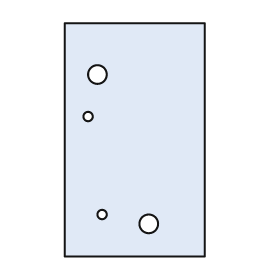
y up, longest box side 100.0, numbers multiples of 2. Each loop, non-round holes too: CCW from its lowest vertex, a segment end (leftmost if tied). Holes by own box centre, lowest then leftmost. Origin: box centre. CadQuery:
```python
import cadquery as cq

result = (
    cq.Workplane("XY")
    .moveTo(-30.0, -50.0)
    .lineTo(30.0, -50.0)
    .lineTo(30.0, 50.0)
    .lineTo(-30.0, 50.0)
    .close()
    .moveTo(6.0, -36.0)
    .circle(4.0)
    .moveTo(-14.0, -32.0)
    .circle(2.0)
    .moveTo(-20.0, 10.0)
    .circle(2.0)
    .moveTo(-16.0, 28.0)
    .circle(4.0)
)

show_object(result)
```